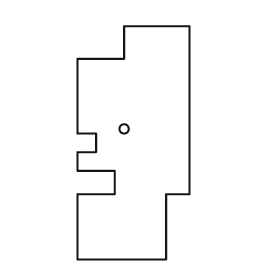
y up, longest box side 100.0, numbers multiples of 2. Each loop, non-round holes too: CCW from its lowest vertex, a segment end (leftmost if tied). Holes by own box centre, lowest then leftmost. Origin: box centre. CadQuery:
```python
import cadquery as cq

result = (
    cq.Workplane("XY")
    .moveTo(-24.0, -50.0)
    .lineTo(14.0, -50.0)
    .lineTo(14.0, -22.0)
    .lineTo(24.0, -22.0)
    .lineTo(24.0, 50.0)
    .lineTo(-4.0, 50.0)
    .lineTo(-4.0, 36.0)
    .lineTo(-24.0, 36.0)
    .lineTo(-24.0, 4.0)
    .lineTo(-16.0, 4.0)
    .lineTo(-16.0, -4.0)
    .lineTo(-24.0, -4.0)
    .lineTo(-24.0, -12.0)
    .lineTo(-8.0, -12.0)
    .lineTo(-8.0, -22.0)
    .lineTo(-24.0, -22.0)
    .close()
    .moveTo(-4.0, 6.0)
    .circle(2.0)
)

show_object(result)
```